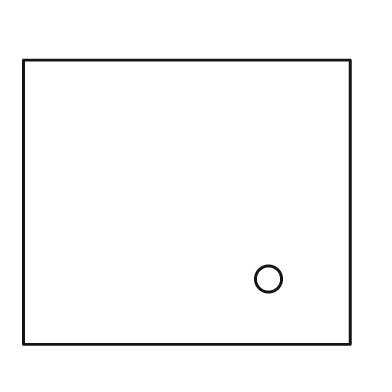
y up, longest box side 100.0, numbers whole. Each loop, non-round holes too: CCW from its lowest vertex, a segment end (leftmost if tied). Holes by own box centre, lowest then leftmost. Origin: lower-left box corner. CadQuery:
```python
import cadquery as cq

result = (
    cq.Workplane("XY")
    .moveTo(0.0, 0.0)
    .lineTo(100.0, 0.0)
    .lineTo(100.0, 87.0)
    .lineTo(0.0, 87.0)
    .close()
    .moveTo(75.0, 20.0)
    .circle(4.0)
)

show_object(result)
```